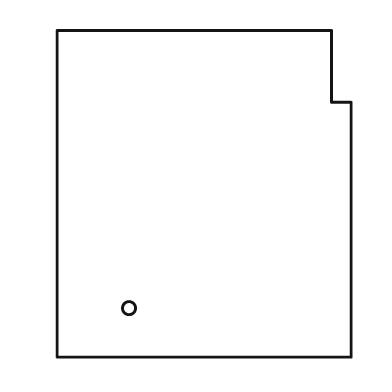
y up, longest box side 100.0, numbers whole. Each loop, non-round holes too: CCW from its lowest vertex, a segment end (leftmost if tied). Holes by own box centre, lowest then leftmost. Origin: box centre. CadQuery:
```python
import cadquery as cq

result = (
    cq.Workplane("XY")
    .moveTo(-45.0, -50.0)
    .lineTo(45.0, -50.0)
    .lineTo(45.0, 28.0)
    .lineTo(39.0, 28.0)
    .lineTo(39.0, 50.0)
    .lineTo(-45.0, 50.0)
    .close()
    .moveTo(-23.0, -35.0)
    .circle(2.0)
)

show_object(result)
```